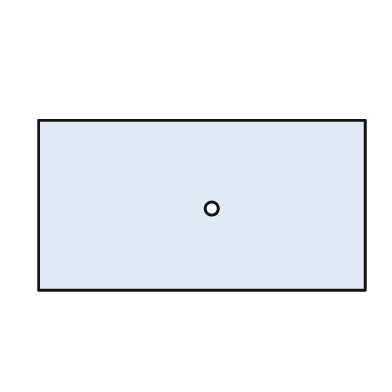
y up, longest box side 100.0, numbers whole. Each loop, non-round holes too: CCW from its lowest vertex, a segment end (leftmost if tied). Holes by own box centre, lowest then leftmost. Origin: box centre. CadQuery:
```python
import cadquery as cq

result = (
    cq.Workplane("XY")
    .moveTo(-50.0, -26.0)
    .lineTo(50.0, -26.0)
    .lineTo(50.0, 26.0)
    .lineTo(-50.0, 26.0)
    .close()
    .moveTo(3.0, -1.0)
    .circle(2.0)
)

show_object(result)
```